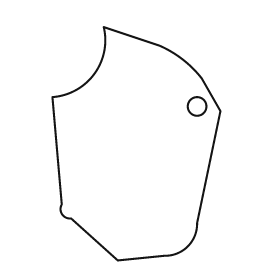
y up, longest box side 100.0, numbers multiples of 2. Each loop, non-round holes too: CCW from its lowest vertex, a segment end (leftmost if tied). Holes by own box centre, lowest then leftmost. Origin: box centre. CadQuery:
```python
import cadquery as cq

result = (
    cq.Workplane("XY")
    .moveTo(-8.0, -50.0)
    .lineTo(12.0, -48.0)
    .threePointArc((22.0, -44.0), (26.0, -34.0))
    .lineTo(36.0, 14.0)
    .lineTo(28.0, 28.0)
    .threePointArc((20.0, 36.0), (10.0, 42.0))
    .lineTo(-14.0, 50.0)
    .threePointArc((-18.0, 30.0), (-36.0, 20.0))
    .lineTo(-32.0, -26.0)
    .threePointArc((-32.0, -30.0), (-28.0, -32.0))
    .close()
    .moveTo(26.0, 16.0)
    .circle(4.0)
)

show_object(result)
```